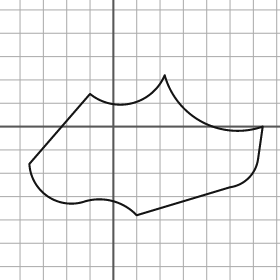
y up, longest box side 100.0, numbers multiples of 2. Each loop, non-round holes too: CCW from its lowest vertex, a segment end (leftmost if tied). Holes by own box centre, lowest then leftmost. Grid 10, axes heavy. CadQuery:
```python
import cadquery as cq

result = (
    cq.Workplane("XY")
    .moveTo(10.0, -38.0)
    .lineTo(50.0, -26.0)
    .threePointArc((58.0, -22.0), (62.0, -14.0))
    .lineTo(64.0, 0.0)
    .threePointArc((38.0, 2.0), (22.0, 22.0))
    .threePointArc((8.0, 10.0), (-10.0, 14.0))
    .lineTo(-36.0, -16.0)
    .threePointArc((-28.0, -30.0), (-12.0, -32.0))
    .threePointArc((0.0, -32.0), (10.0, -38.0))
    .close()
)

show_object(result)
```